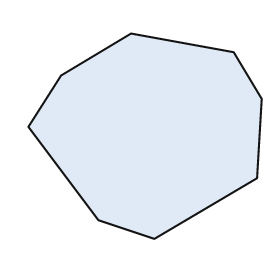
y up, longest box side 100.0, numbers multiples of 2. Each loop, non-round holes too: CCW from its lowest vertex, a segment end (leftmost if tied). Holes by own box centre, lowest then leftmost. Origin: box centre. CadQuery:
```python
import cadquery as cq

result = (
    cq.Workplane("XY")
    .moveTo(4.0, -44.0)
    .lineTo(48.0, -18.0)
    .lineTo(50.0, 16.0)
    .lineTo(38.0, 36.0)
    .lineTo(-6.0, 44.0)
    .lineTo(-36.0, 26.0)
    .lineTo(-50.0, 4.0)
    .lineTo(-20.0, -36.0)
    .close()
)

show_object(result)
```